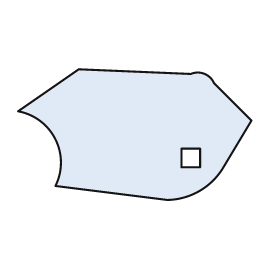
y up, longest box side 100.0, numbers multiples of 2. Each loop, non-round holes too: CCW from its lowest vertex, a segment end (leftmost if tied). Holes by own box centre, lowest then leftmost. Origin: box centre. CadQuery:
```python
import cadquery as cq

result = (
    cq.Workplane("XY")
    .moveTo(14.0, -28.0)
    .threePointArc((28.0, -24.0), (38.0, -14.0))
    .lineTo(50.0, 6.0)
    .lineTo(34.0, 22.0)
    .threePointArc((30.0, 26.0), (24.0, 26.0))
    .lineTo(-24.0, 28.0)
    .lineTo(-50.0, 10.0)
    .threePointArc((-34.0, -2.0), (-34.0, -22.0))
    .close()
    .moveTo(20.0, -14.0)
    .lineTo(28.0, -14.0)
    .lineTo(28.0, -6.0)
    .lineTo(20.0, -6.0)
    .close()
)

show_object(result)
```